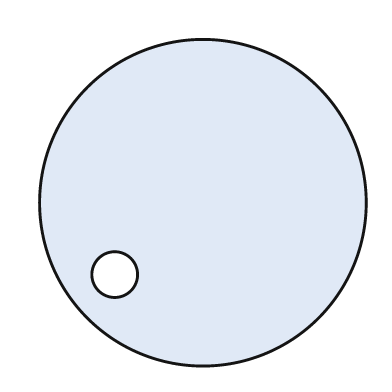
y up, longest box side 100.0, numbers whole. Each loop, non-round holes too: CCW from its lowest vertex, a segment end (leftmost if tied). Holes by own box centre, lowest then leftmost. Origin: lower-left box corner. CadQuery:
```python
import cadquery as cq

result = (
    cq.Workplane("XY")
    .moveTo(50.0, 50.0)
    .circle(50.0)
    .moveTo(23.0, 28.0)
    .circle(7.0)
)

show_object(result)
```